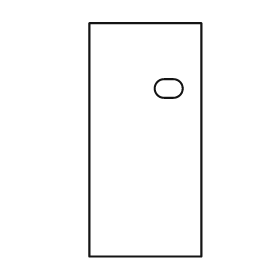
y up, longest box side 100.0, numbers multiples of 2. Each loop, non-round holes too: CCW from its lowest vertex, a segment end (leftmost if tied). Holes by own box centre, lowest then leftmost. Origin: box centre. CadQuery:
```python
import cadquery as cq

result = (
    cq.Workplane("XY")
    .moveTo(-24.0, -50.0)
    .lineTo(24.0, -50.0)
    .lineTo(24.0, 50.0)
    .lineTo(-24.0, 50.0)
    .close()
    .moveTo(8.0, 18.0)
    .lineTo(12.0, 18.0)
    .threePointArc((16.0, 22.0), (12.0, 26.0))
    .lineTo(8.0, 26.0)
    .threePointArc((4.0, 22.0), (8.0, 18.0))
    .close()
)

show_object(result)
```